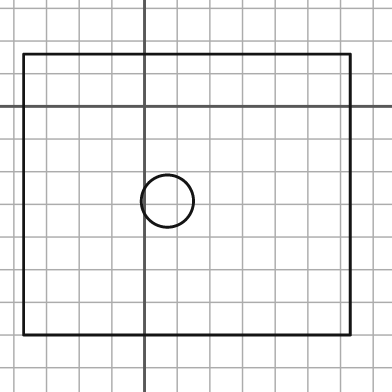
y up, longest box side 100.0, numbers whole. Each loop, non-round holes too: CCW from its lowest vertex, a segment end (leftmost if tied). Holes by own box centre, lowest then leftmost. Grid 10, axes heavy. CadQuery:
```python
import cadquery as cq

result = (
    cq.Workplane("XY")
    .moveTo(-37.0, -70.0)
    .lineTo(63.0, -70.0)
    .lineTo(63.0, 16.0)
    .lineTo(-37.0, 16.0)
    .close()
    .moveTo(7.0, -29.0)
    .circle(8.0)
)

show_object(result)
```